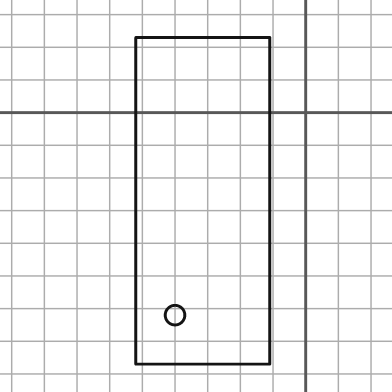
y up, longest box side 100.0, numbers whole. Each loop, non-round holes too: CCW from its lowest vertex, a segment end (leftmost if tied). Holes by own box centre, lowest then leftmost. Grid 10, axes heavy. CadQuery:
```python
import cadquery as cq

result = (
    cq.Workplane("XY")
    .moveTo(-52.0, -77.0)
    .lineTo(-11.0, -77.0)
    .lineTo(-11.0, 23.0)
    .lineTo(-52.0, 23.0)
    .close()
    .moveTo(-40.0, -62.0)
    .circle(3.0)
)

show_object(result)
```